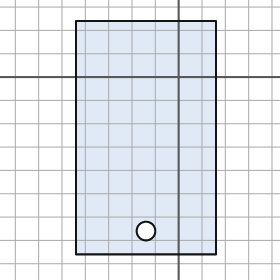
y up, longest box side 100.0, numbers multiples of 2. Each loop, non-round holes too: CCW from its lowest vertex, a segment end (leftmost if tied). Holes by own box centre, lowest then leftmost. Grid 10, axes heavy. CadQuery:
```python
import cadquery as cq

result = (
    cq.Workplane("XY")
    .moveTo(-44.0, -76.0)
    .lineTo(16.0, -76.0)
    .lineTo(16.0, 24.0)
    .lineTo(-44.0, 24.0)
    .close()
    .moveTo(-14.0, -66.0)
    .circle(4.0)
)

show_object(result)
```